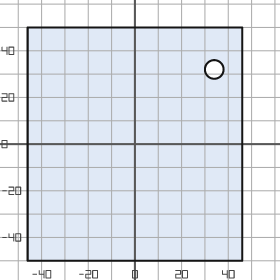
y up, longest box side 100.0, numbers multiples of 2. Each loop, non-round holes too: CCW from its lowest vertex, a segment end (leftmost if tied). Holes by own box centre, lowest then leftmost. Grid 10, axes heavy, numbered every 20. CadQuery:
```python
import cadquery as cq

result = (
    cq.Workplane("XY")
    .moveTo(-46.0, -50.0)
    .lineTo(46.0, -50.0)
    .lineTo(46.0, 50.0)
    .lineTo(-46.0, 50.0)
    .close()
    .moveTo(34.0, 32.0)
    .circle(4.0)
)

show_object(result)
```